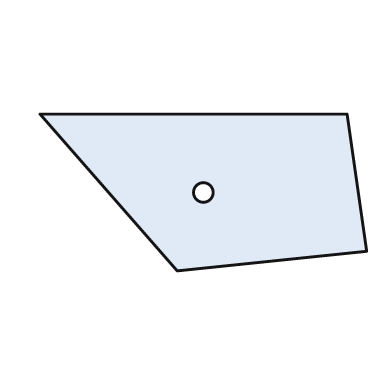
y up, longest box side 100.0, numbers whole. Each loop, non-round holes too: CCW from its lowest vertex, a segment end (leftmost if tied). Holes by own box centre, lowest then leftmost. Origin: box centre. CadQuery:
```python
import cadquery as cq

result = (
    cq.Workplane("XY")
    .moveTo(-8.0, -24.0)
    .lineTo(50.0, -18.0)
    .lineTo(44.0, 24.0)
    .lineTo(-50.0, 24.0)
    .close()
    .moveTo(0.0, 0.0)
    .circle(3.0)
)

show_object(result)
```